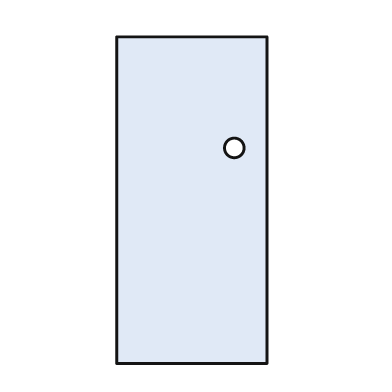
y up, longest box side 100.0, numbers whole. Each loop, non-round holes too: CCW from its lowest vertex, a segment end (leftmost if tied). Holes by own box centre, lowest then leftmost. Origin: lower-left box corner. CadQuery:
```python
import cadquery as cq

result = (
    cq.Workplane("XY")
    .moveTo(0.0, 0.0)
    .lineTo(46.0, 0.0)
    .lineTo(46.0, 100.0)
    .lineTo(0.0, 100.0)
    .close()
    .moveTo(36.0, 66.0)
    .circle(3.0)
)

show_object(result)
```